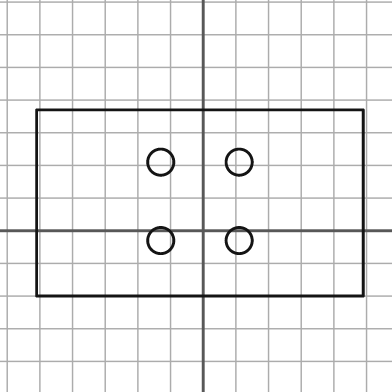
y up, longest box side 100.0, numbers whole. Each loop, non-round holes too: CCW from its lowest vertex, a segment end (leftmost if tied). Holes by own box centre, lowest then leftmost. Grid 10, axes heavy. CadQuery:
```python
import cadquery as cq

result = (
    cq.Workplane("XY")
    .moveTo(-51.0, -20.0)
    .lineTo(49.0, -20.0)
    .lineTo(49.0, 37.0)
    .lineTo(-51.0, 37.0)
    .close()
    .moveTo(-13.0, -3.0)
    .circle(4.0)
    .moveTo(11.0, -3.0)
    .circle(4.0)
    .moveTo(-13.0, 21.0)
    .circle(4.0)
    .moveTo(11.0, 21.0)
    .circle(4.0)
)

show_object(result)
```